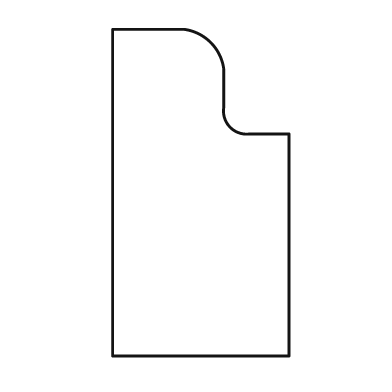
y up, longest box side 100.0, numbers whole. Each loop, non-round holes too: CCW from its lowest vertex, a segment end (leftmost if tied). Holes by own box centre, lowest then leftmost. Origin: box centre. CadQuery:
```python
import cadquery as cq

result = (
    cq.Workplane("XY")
    .moveTo(-27.0, -50.0)
    .lineTo(27.0, -50.0)
    .lineTo(27.0, 18.0)
    .lineTo(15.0, 18.0)
    .threePointArc((9.0, 20.0), (7.0, 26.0))
    .lineTo(7.0, 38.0)
    .threePointArc((3.0, 46.0), (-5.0, 50.0))
    .lineTo(-27.0, 50.0)
    .close()
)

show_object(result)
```